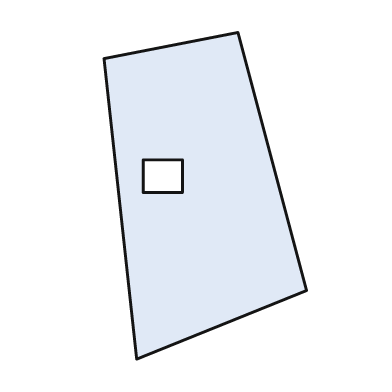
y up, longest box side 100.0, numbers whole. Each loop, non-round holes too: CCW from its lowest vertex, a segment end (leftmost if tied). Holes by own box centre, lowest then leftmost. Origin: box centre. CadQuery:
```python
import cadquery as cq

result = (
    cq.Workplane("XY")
    .moveTo(-21.0, -50.0)
    .lineTo(31.0, -29.0)
    .lineTo(10.0, 50.0)
    .lineTo(-31.0, 42.0)
    .close()
    .moveTo(-19.0, 1.0)
    .lineTo(-7.0, 1.0)
    .lineTo(-7.0, 11.0)
    .lineTo(-19.0, 11.0)
    .close()
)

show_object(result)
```